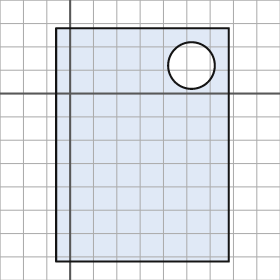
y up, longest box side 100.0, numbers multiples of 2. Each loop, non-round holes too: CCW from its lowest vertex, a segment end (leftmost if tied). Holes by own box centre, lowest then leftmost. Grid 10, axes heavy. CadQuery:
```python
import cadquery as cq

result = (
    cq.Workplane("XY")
    .moveTo(-6.0, -72.0)
    .lineTo(68.0, -72.0)
    .lineTo(68.0, 28.0)
    .lineTo(-6.0, 28.0)
    .close()
    .moveTo(52.0, 12.0)
    .circle(10.0)
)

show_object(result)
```